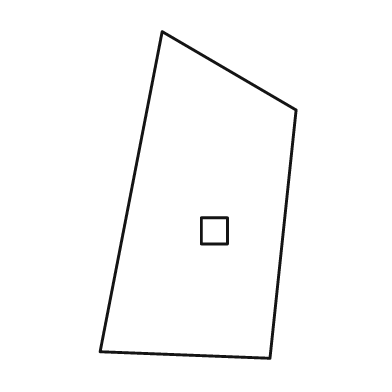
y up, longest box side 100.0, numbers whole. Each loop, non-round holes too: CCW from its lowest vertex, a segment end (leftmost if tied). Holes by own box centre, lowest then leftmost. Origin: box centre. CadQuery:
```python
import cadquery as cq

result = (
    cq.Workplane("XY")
    .moveTo(22.0, -50.0)
    .lineTo(30.0, 26.0)
    .lineTo(-11.0, 50.0)
    .lineTo(-30.0, -48.0)
    .close()
    .moveTo(1.0, -15.0)
    .lineTo(9.0, -15.0)
    .lineTo(9.0, -7.0)
    .lineTo(1.0, -7.0)
    .close()
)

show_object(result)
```